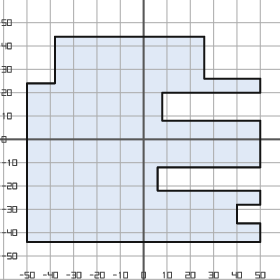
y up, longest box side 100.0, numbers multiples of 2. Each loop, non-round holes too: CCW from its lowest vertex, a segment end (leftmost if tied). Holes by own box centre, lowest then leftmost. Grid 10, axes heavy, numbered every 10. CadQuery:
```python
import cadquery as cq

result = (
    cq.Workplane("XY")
    .moveTo(-50.0, -44.0)
    .lineTo(50.0, -44.0)
    .lineTo(50.0, -36.0)
    .lineTo(40.0, -36.0)
    .lineTo(40.0, -28.0)
    .lineTo(50.0, -28.0)
    .lineTo(50.0, -22.0)
    .lineTo(6.0, -22.0)
    .lineTo(6.0, -12.0)
    .lineTo(50.0, -12.0)
    .lineTo(50.0, 8.0)
    .lineTo(8.0, 8.0)
    .lineTo(8.0, 20.0)
    .lineTo(50.0, 20.0)
    .lineTo(50.0, 26.0)
    .lineTo(26.0, 26.0)
    .lineTo(26.0, 44.0)
    .lineTo(-38.0, 44.0)
    .lineTo(-38.0, 24.0)
    .lineTo(-50.0, 24.0)
    .close()
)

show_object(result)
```